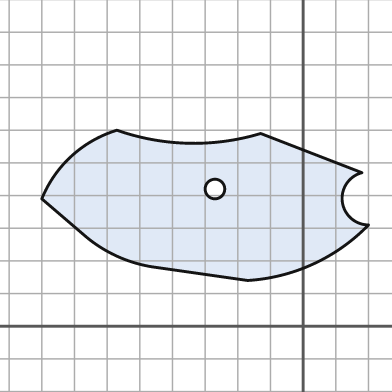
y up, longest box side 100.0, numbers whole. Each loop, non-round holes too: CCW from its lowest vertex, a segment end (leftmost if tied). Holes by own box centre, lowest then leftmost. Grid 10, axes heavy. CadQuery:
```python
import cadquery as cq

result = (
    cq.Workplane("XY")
    .moveTo(-17.0, 14.0)
    .threePointArc((3.0, 19.0), (20.0, 31.0))
    .threePointArc((12.0, 38.0), (18.0, 47.0))
    .lineTo(-13.0, 59.0)
    .threePointArc((-35.0, 56.0), (-57.0, 60.0))
    .threePointArc((-71.0, 52.0), (-80.0, 39.0))
    .lineTo(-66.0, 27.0)
    .threePointArc((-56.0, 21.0), (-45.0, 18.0))
    .close()
    .moveTo(-27.0, 42.0)
    .circle(3.0)
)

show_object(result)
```